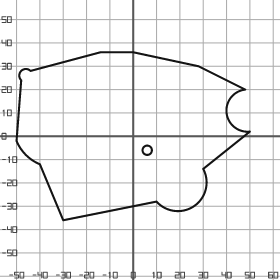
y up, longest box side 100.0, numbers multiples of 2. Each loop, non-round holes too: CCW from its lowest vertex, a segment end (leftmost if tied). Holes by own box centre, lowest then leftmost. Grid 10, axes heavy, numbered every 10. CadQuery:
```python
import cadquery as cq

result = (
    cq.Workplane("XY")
    .moveTo(-30.0, -36.0)
    .lineTo(10.0, -28.0)
    .threePointArc((26.0, -30.0), (30.0, -14.0))
    .lineTo(50.0, 2.0)
    .threePointArc((40.0, 10.0), (48.0, 20.0))
    .lineTo(28.0, 30.0)
    .lineTo(0.0, 36.0)
    .lineTo(-14.0, 36.0)
    .lineTo(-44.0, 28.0)
    .threePointArc((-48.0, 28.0), (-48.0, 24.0))
    .lineTo(-50.0, -2.0)
    .threePointArc((-46.0, -8.0), (-40.0, -12.0))
    .close()
    .moveTo(6.0, -6.0)
    .circle(2.0)
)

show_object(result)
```